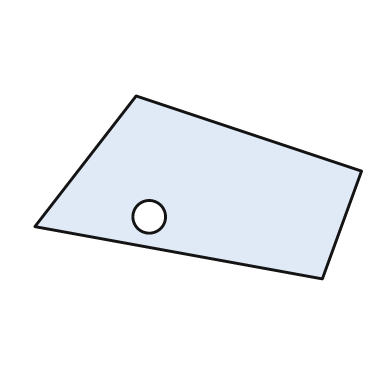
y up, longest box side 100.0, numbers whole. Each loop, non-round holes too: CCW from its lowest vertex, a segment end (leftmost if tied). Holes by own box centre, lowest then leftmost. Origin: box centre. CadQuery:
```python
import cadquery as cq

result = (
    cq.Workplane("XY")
    .moveTo(38.0, -28.0)
    .lineTo(50.0, 5.0)
    .lineTo(-19.0, 28.0)
    .lineTo(-50.0, -12.0)
    .close()
    .moveTo(-15.0, -9.0)
    .circle(5.0)
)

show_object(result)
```